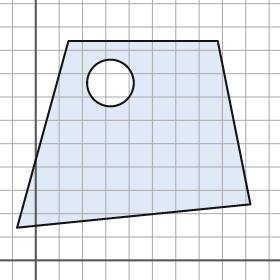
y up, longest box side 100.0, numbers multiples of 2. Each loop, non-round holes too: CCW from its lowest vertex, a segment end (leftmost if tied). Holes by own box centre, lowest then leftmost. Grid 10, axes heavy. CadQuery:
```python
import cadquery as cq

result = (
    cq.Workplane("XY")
    .moveTo(-8.0, 14.0)
    .lineTo(92.0, 24.0)
    .lineTo(78.0, 94.0)
    .lineTo(14.0, 94.0)
    .close()
    .moveTo(32.0, 76.0)
    .circle(10.0)
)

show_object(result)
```